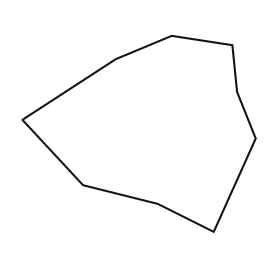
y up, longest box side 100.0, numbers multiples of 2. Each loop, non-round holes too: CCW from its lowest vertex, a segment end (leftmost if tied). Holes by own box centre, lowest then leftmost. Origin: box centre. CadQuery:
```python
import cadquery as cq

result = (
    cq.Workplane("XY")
    .moveTo(32.0, -42.0)
    .lineTo(50.0, -2.0)
    .lineTo(42.0, 18.0)
    .lineTo(40.0, 38.0)
    .lineTo(14.0, 42.0)
    .lineTo(-10.0, 32.0)
    .lineTo(-50.0, 6.0)
    .lineTo(-24.0, -22.0)
    .lineTo(8.0, -30.0)
    .close()
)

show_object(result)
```